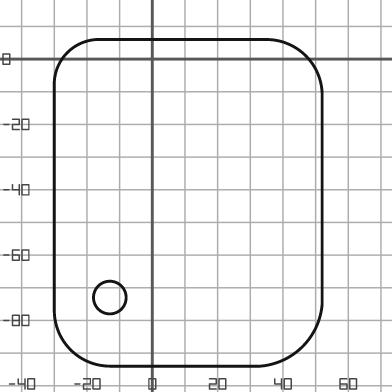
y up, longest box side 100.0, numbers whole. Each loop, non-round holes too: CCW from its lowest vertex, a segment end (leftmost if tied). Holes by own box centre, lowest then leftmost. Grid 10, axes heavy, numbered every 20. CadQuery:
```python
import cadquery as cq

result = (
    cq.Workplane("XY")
    .moveTo(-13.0, -94.0)
    .lineTo(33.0, -94.0)
    .threePointArc((46.0, -88.0), (52.0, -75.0))
    .lineTo(52.0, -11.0)
    .threePointArc((47.0, 1.0), (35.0, 6.0))
    .lineTo(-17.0, 6.0)
    .threePointArc((-26.0, 2.0), (-30.0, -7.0))
    .lineTo(-30.0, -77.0)
    .threePointArc((-25.0, -89.0), (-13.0, -94.0))
    .close()
    .moveTo(-13.0, -73.0)
    .circle(5.0)
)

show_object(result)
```